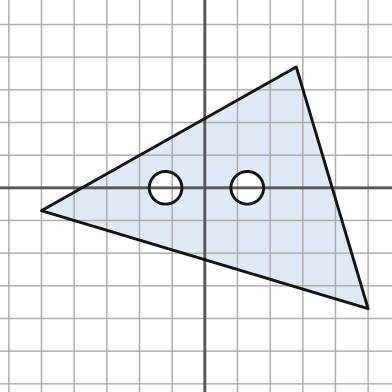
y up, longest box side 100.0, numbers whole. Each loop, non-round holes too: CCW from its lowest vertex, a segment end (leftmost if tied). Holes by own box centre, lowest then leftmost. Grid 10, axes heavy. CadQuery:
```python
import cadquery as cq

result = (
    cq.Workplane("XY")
    .moveTo(50.0, -37.0)
    .lineTo(28.0, 37.0)
    .lineTo(-50.0, -7.0)
    .close()
    .moveTo(-12.0, 0.0)
    .circle(5.0)
    .moveTo(13.0, 0.0)
    .circle(5.0)
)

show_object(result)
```